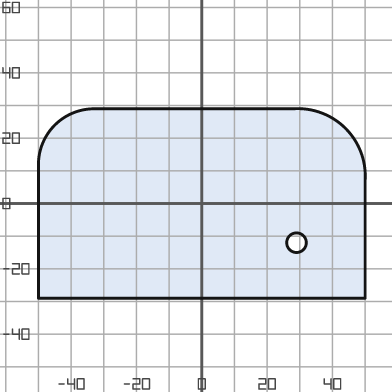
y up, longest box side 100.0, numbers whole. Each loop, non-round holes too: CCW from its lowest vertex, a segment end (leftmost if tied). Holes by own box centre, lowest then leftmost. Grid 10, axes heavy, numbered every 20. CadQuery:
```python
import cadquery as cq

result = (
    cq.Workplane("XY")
    .moveTo(-50.0, -29.0)
    .lineTo(50.0, -29.0)
    .lineTo(50.0, 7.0)
    .threePointArc((44.0, 23.0), (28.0, 29.0))
    .lineTo(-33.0, 29.0)
    .threePointArc((-45.0, 24.0), (-50.0, 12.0))
    .close()
    .moveTo(29.0, -12.0)
    .circle(3.0)
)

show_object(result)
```